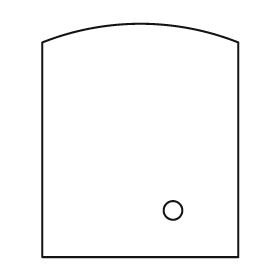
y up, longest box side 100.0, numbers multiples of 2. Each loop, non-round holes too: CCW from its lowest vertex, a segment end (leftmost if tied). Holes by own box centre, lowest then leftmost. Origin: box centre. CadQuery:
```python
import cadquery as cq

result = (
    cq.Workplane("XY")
    .moveTo(-42.0, -50.0)
    .lineTo(42.0, -50.0)
    .lineTo(42.0, 42.0)
    .threePointArc((0.0, 50.0), (-42.0, 42.0))
    .close()
    .moveTo(14.0, -30.0)
    .circle(4.0)
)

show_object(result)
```